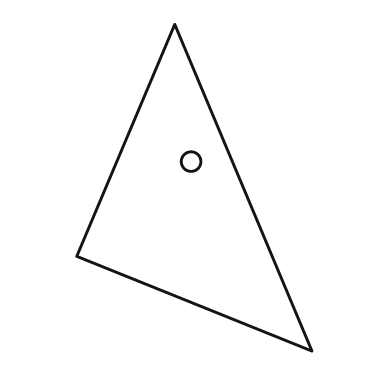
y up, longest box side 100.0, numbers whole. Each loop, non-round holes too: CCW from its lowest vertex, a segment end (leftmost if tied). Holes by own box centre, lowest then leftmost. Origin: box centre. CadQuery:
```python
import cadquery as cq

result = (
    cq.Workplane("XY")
    .moveTo(36.0, -50.0)
    .lineTo(-6.0, 50.0)
    .lineTo(-36.0, -21.0)
    .close()
    .moveTo(-1.0, 8.0)
    .circle(3.0)
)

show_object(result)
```